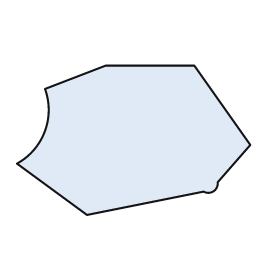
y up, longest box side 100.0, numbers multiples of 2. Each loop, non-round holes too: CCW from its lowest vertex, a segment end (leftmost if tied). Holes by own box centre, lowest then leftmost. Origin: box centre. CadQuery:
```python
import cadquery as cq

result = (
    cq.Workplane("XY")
    .moveTo(-20.0, -32.0)
    .lineTo(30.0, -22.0)
    .threePointArc((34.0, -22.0), (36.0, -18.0))
    .lineTo(50.0, -2.0)
    .lineTo(26.0, 32.0)
    .lineTo(-12.0, 32.0)
    .lineTo(-38.0, 22.0)
    .threePointArc((-38.0, 4.0), (-50.0, -10.0))
    .close()
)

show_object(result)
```